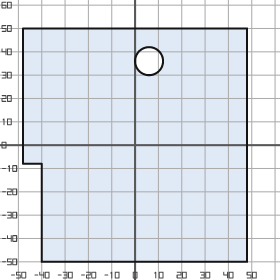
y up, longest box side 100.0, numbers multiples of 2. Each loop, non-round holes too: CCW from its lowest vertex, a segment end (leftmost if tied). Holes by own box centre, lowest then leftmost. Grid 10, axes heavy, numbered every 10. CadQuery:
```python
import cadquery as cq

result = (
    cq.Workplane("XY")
    .moveTo(-40.0, -50.0)
    .lineTo(48.0, -50.0)
    .lineTo(48.0, 50.0)
    .lineTo(-48.0, 50.0)
    .lineTo(-48.0, -8.0)
    .lineTo(-40.0, -8.0)
    .close()
    .moveTo(6.0, 36.0)
    .circle(6.0)
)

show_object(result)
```